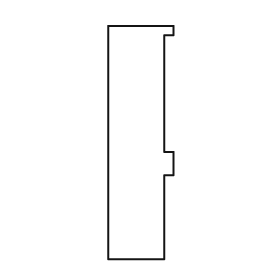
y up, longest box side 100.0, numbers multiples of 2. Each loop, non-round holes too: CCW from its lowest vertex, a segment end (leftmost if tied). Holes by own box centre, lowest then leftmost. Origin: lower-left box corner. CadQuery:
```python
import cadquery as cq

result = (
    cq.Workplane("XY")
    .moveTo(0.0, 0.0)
    .lineTo(24.0, 0.0)
    .lineTo(24.0, 36.0)
    .lineTo(28.0, 36.0)
    .lineTo(28.0, 46.0)
    .lineTo(24.0, 46.0)
    .lineTo(24.0, 96.0)
    .lineTo(28.0, 96.0)
    .lineTo(28.0, 100.0)
    .lineTo(0.0, 100.0)
    .close()
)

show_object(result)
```